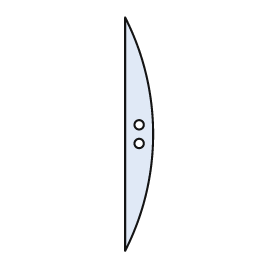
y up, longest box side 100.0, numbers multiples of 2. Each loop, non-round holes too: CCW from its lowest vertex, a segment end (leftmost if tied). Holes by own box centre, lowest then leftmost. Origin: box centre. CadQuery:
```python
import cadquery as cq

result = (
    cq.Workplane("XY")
    .moveTo(-6.0, -50.0)
    .threePointArc((6.0, 0.0), (-6.0, 50.0))
    .close()
    .moveTo(0.0, -4.0)
    .circle(2.0)
    .moveTo(0.0, 4.0)
    .circle(2.0)
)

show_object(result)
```